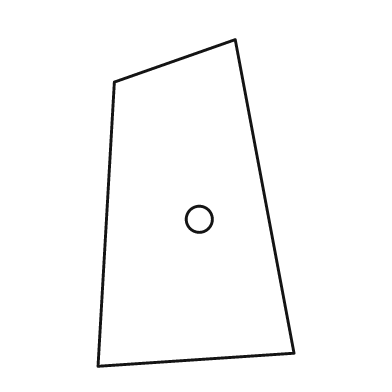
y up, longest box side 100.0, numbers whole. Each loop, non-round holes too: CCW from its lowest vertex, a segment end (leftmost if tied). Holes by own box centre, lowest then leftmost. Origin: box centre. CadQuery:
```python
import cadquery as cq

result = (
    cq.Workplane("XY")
    .moveTo(-30.0, -50.0)
    .lineTo(30.0, -46.0)
    .lineTo(12.0, 50.0)
    .lineTo(-25.0, 37.0)
    .close()
    .moveTo(1.0, -5.0)
    .circle(4.0)
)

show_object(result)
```